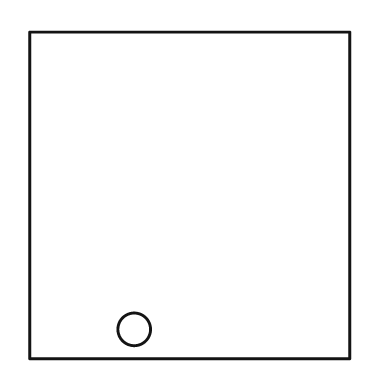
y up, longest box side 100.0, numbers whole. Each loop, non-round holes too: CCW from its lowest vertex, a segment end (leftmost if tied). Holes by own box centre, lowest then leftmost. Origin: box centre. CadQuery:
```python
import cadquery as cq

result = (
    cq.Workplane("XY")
    .moveTo(-49.0, -50.0)
    .lineTo(49.0, -50.0)
    .lineTo(49.0, 50.0)
    .lineTo(-49.0, 50.0)
    .close()
    .moveTo(-17.0, -41.0)
    .circle(5.0)
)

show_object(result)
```